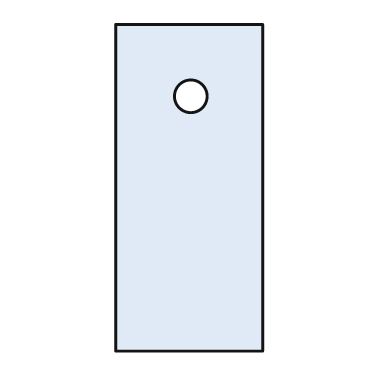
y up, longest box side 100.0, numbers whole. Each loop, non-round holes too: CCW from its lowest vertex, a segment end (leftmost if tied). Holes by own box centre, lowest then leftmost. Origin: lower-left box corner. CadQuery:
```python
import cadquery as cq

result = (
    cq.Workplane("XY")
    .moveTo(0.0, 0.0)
    .lineTo(45.0, 0.0)
    .lineTo(45.0, 100.0)
    .lineTo(0.0, 100.0)
    .close()
    .moveTo(23.0, 78.0)
    .circle(5.0)
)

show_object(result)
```